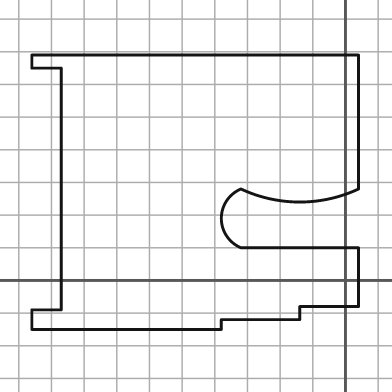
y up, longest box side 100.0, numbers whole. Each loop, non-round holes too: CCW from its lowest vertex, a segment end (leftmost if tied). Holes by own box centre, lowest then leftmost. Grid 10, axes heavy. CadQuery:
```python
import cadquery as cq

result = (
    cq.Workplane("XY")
    .moveTo(-96.0, -15.0)
    .lineTo(-38.0, -15.0)
    .lineTo(-38.0, -12.0)
    .lineTo(-14.0, -12.0)
    .lineTo(-14.0, -8.0)
    .lineTo(4.0, -8.0)
    .lineTo(4.0, 10.0)
    .lineTo(-32.0, 10.0)
    .threePointArc((-38.0, 19.0), (-32.0, 28.0))
    .threePointArc((-14.0, 24.0), (4.0, 28.0))
    .lineTo(4.0, 69.0)
    .lineTo(-96.0, 69.0)
    .lineTo(-96.0, 65.0)
    .lineTo(-87.0, 65.0)
    .lineTo(-87.0, -9.0)
    .lineTo(-96.0, -9.0)
    .close()
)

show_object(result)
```